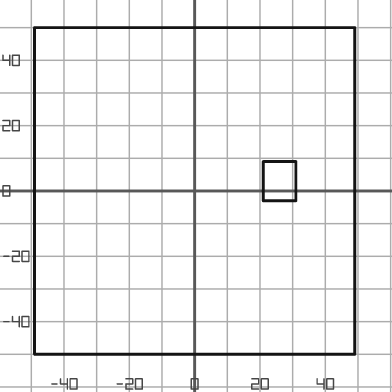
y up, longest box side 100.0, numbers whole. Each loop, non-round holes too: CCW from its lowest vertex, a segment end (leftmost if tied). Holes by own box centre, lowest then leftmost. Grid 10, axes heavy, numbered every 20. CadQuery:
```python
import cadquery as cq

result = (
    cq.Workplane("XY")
    .moveTo(-49.0, -50.0)
    .lineTo(49.0, -50.0)
    .lineTo(49.0, 50.0)
    .lineTo(-49.0, 50.0)
    .close()
    .moveTo(21.0, -3.0)
    .lineTo(31.0, -3.0)
    .lineTo(31.0, 9.0)
    .lineTo(21.0, 9.0)
    .close()
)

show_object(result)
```